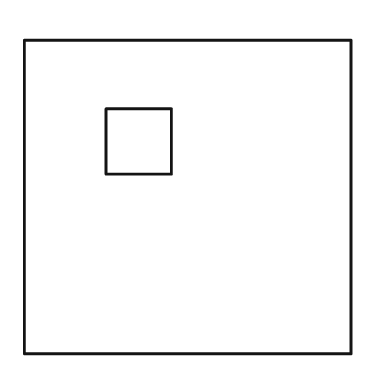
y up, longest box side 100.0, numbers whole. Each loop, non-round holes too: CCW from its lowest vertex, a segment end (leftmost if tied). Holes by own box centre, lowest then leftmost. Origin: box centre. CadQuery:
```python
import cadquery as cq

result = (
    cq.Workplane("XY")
    .moveTo(-50.0, -48.0)
    .lineTo(50.0, -48.0)
    .lineTo(50.0, 48.0)
    .lineTo(-50.0, 48.0)
    .close()
    .moveTo(-25.0, 7.0)
    .lineTo(-5.0, 7.0)
    .lineTo(-5.0, 27.0)
    .lineTo(-25.0, 27.0)
    .close()
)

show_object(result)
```